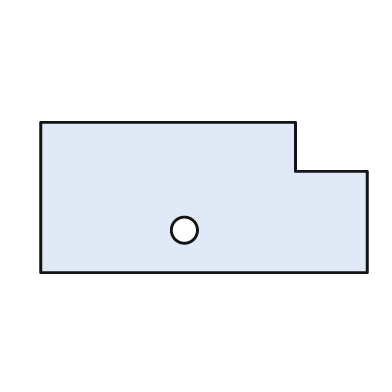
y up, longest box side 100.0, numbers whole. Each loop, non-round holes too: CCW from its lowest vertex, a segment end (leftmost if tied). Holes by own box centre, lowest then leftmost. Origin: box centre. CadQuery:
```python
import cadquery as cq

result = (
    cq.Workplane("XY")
    .moveTo(-50.0, -23.0)
    .lineTo(50.0, -23.0)
    .lineTo(50.0, 8.0)
    .lineTo(28.0, 8.0)
    .lineTo(28.0, 23.0)
    .lineTo(-50.0, 23.0)
    .close()
    .moveTo(-6.0, -10.0)
    .circle(4.0)
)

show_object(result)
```